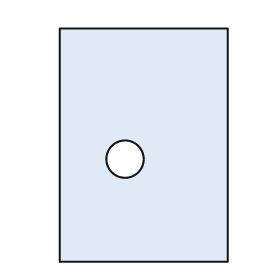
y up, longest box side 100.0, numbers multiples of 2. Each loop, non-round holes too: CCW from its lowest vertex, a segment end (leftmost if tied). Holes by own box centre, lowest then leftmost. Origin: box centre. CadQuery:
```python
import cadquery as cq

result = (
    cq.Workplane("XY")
    .moveTo(-36.0, -50.0)
    .lineTo(36.0, -50.0)
    .lineTo(36.0, 50.0)
    .lineTo(-36.0, 50.0)
    .close()
    .moveTo(-8.0, -6.0)
    .circle(8.0)
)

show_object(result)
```